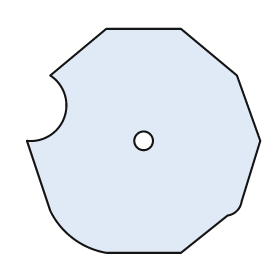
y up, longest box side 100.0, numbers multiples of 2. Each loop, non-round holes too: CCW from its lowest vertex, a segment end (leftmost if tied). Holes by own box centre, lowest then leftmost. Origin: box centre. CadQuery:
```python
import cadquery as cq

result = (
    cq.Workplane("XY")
    .moveTo(-16.0, -48.0)
    .lineTo(16.0, -48.0)
    .lineTo(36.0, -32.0)
    .threePointArc((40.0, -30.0), (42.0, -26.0))
    .lineTo(50.0, 0.0)
    .lineTo(40.0, 28.0)
    .lineTo(16.0, 48.0)
    .lineTo(-16.0, 48.0)
    .lineTo(-40.0, 28.0)
    .threePointArc((-34.0, 10.0), (-50.0, 0.0))
    .lineTo(-40.0, -30.0)
    .threePointArc((-30.0, -42.0), (-16.0, -48.0))
    .close()
    .moveTo(0.0, 0.0)
    .circle(4.0)
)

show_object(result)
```